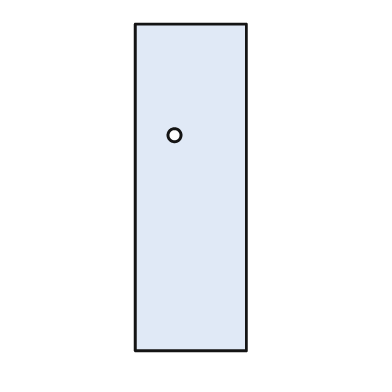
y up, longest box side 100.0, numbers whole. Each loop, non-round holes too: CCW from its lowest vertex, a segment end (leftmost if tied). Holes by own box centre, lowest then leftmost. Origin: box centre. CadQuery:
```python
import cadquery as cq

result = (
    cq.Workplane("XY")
    .moveTo(-17.0, -50.0)
    .lineTo(17.0, -50.0)
    .lineTo(17.0, 50.0)
    .lineTo(-17.0, 50.0)
    .close()
    .moveTo(-5.0, 16.0)
    .circle(2.0)
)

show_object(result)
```